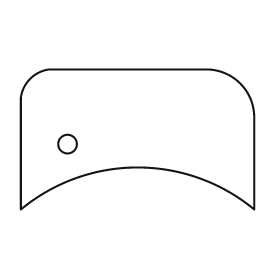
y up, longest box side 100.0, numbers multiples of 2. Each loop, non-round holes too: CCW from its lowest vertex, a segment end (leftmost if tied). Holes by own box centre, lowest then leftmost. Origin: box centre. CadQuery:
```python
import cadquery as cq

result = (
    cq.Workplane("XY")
    .moveTo(-50.0, -30.0)
    .threePointArc((0.0, -12.0), (50.0, -30.0))
    .lineTo(50.0, 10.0)
    .threePointArc((44.0, 24.0), (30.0, 30.0))
    .lineTo(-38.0, 30.0)
    .threePointArc((-46.0, 26.0), (-50.0, 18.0))
    .close()
    .moveTo(-30.0, -2.0)
    .circle(4.0)
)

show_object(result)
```